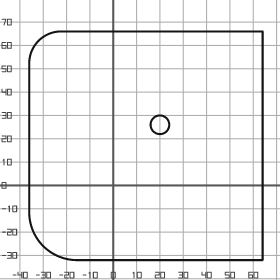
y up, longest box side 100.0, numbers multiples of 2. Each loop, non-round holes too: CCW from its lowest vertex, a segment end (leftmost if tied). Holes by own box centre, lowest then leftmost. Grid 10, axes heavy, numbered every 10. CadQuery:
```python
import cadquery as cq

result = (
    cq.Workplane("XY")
    .moveTo(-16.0, -32.0)
    .lineTo(64.0, -32.0)
    .lineTo(64.0, 66.0)
    .lineTo(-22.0, 66.0)
    .threePointArc((-32.0, 62.0), (-36.0, 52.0))
    .lineTo(-36.0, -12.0)
    .threePointArc((-30.0, -26.0), (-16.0, -32.0))
    .close()
    .moveTo(20.0, 26.0)
    .circle(4.0)
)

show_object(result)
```